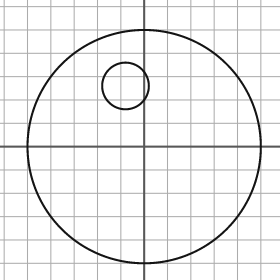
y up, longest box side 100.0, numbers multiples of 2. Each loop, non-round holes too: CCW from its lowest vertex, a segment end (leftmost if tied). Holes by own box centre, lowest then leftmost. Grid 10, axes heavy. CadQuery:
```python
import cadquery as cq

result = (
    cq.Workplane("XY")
    .moveTo(0.0, 0.0)
    .circle(50.0)
    .moveTo(-8.0, 26.0)
    .circle(10.0)
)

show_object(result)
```